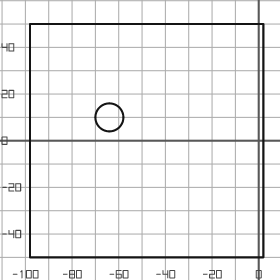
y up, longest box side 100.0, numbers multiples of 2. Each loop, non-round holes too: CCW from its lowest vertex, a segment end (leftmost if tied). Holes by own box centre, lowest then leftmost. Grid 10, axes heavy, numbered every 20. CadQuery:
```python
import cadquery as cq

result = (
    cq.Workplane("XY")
    .moveTo(-98.0, -50.0)
    .lineTo(2.0, -50.0)
    .lineTo(2.0, 50.0)
    .lineTo(-98.0, 50.0)
    .close()
    .moveTo(-64.0, 10.0)
    .circle(6.0)
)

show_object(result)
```